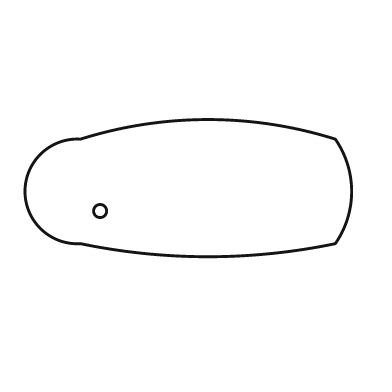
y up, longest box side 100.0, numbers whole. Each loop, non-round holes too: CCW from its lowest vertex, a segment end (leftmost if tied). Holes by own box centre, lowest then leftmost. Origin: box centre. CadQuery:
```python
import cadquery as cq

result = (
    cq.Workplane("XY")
    .moveTo(-33.0, -17.0)
    .threePointArc((6.0, -21.0), (45.0, -17.0))
    .threePointArc((50.0, -1.0), (45.0, 15.0))
    .threePointArc((6.0, 21.0), (-33.0, 15.0))
    .threePointArc((-50.0, -1.0), (-33.0, -17.0))
    .close()
    .moveTo(-27.0, -7.0)
    .circle(2.0)
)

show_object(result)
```